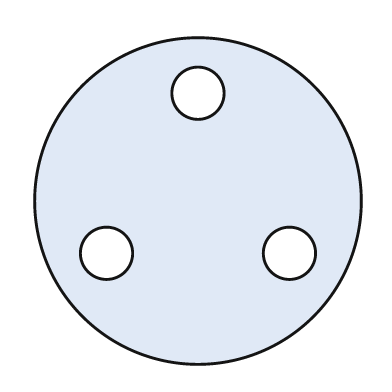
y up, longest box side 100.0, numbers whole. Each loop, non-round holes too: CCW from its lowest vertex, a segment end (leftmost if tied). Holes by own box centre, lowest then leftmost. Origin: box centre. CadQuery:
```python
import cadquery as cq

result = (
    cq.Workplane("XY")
    .moveTo(0.0, 0.0)
    .circle(50.0)
    .moveTo(-28.0, -16.0)
    .circle(8.0)
    .moveTo(28.0, -16.0)
    .circle(8.0)
    .moveTo(0.0, 33.0)
    .circle(8.0)
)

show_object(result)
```